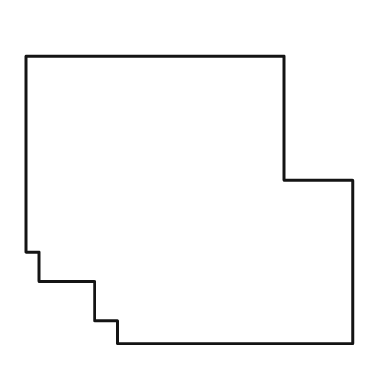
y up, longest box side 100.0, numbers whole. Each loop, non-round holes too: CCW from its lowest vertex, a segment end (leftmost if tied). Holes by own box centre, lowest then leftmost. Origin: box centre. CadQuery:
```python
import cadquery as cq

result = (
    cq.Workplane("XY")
    .moveTo(-22.0, -44.0)
    .lineTo(50.0, -44.0)
    .lineTo(50.0, 6.0)
    .lineTo(29.0, 6.0)
    .lineTo(29.0, 44.0)
    .lineTo(-50.0, 44.0)
    .lineTo(-50.0, -16.0)
    .lineTo(-46.0, -16.0)
    .lineTo(-46.0, -25.0)
    .lineTo(-29.0, -25.0)
    .lineTo(-29.0, -37.0)
    .lineTo(-22.0, -37.0)
    .close()
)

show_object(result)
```